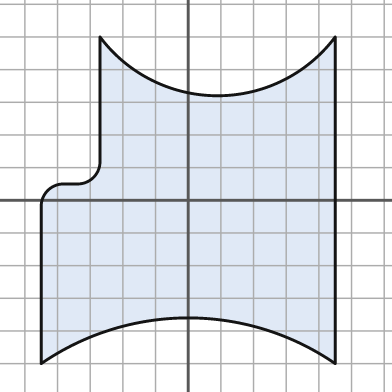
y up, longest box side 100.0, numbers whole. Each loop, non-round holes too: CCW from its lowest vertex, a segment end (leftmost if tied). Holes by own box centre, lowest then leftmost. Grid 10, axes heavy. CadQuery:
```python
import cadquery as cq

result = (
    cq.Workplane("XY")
    .moveTo(-45.0, -50.0)
    .threePointArc((0.0, -36.0), (45.0, -50.0))
    .lineTo(45.0, 50.0)
    .threePointArc((9.0, 32.0), (-27.0, 50.0))
    .lineTo(-27.0, 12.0)
    .threePointArc((-29.0, 7.0), (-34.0, 5.0))
    .lineTo(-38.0, 5.0)
    .threePointArc((-43.0, 3.0), (-45.0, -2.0))
    .close()
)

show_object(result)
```